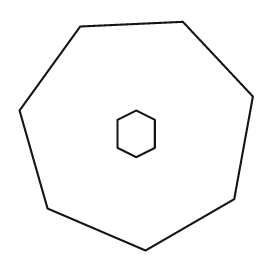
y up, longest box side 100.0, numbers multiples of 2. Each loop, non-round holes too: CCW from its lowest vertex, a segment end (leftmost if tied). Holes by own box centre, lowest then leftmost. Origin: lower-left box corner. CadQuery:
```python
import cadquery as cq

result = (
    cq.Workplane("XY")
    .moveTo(54.0, 0.0)
    .lineTo(92.0, 22.0)
    .lineTo(100.0, 66.0)
    .lineTo(70.0, 98.0)
    .lineTo(26.0, 96.0)
    .lineTo(0.0, 60.0)
    .lineTo(12.0, 18.0)
    .close()
    .moveTo(50.0, 40.0)
    .lineTo(58.0, 44.0)
    .lineTo(58.0, 56.0)
    .lineTo(50.0, 60.0)
    .lineTo(42.0, 56.0)
    .lineTo(42.0, 44.0)
    .close()
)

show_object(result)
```